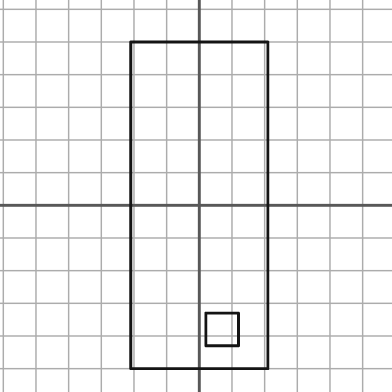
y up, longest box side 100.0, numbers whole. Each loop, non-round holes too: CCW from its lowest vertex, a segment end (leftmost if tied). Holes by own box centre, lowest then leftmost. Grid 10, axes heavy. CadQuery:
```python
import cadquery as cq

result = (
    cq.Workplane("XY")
    .moveTo(-21.0, -50.0)
    .lineTo(21.0, -50.0)
    .lineTo(21.0, 50.0)
    .lineTo(-21.0, 50.0)
    .close()
    .moveTo(2.0, -43.0)
    .lineTo(12.0, -43.0)
    .lineTo(12.0, -33.0)
    .lineTo(2.0, -33.0)
    .close()
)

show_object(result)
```